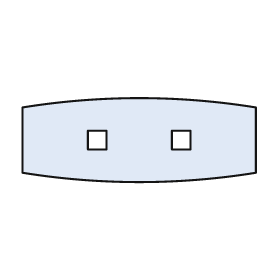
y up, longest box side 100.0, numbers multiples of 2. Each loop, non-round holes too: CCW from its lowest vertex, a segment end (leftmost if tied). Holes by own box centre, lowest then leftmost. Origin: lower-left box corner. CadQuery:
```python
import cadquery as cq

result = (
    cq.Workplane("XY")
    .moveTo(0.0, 4.0)
    .threePointArc((50.0, 0.0), (100.0, 4.0))
    .lineTo(100.0, 32.0)
    .threePointArc((50.0, 36.0), (0.0, 32.0))
    .close()
    .moveTo(28.0, 14.0)
    .lineTo(36.0, 14.0)
    .lineTo(36.0, 22.0)
    .lineTo(28.0, 22.0)
    .close()
    .moveTo(64.0, 14.0)
    .lineTo(72.0, 14.0)
    .lineTo(72.0, 22.0)
    .lineTo(64.0, 22.0)
    .close()
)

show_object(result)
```